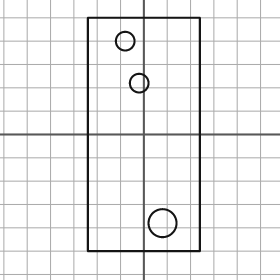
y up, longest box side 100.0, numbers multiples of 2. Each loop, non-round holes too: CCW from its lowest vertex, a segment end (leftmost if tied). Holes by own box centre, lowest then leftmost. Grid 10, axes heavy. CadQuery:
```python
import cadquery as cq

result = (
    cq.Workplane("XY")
    .moveTo(-24.0, -50.0)
    .lineTo(24.0, -50.0)
    .lineTo(24.0, 50.0)
    .lineTo(-24.0, 50.0)
    .close()
    .moveTo(8.0, -38.0)
    .circle(6.0)
    .moveTo(-2.0, 22.0)
    .circle(4.0)
    .moveTo(-8.0, 40.0)
    .circle(4.0)
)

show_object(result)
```